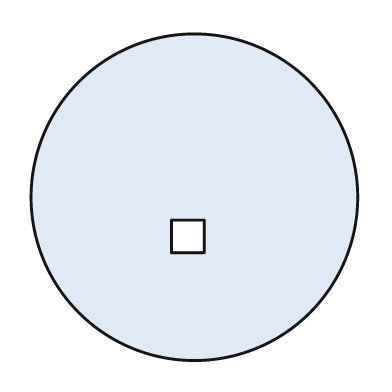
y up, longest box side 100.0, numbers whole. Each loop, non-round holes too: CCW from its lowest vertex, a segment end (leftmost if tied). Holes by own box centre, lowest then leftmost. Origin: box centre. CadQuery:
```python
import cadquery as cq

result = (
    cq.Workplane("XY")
    .moveTo(0.0, 0.0)
    .circle(50.0)
    .moveTo(-7.0, -17.0)
    .lineTo(3.0, -17.0)
    .lineTo(3.0, -7.0)
    .lineTo(-7.0, -7.0)
    .close()
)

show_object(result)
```